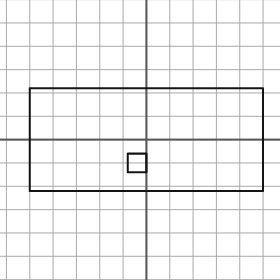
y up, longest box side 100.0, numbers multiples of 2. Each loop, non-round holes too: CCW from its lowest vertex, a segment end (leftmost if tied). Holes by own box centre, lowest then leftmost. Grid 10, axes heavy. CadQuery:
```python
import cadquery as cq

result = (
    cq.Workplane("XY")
    .moveTo(-50.0, -22.0)
    .lineTo(50.0, -22.0)
    .lineTo(50.0, 22.0)
    .lineTo(-50.0, 22.0)
    .close()
    .moveTo(-8.0, -14.0)
    .lineTo(0.0, -14.0)
    .lineTo(0.0, -6.0)
    .lineTo(-8.0, -6.0)
    .close()
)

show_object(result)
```